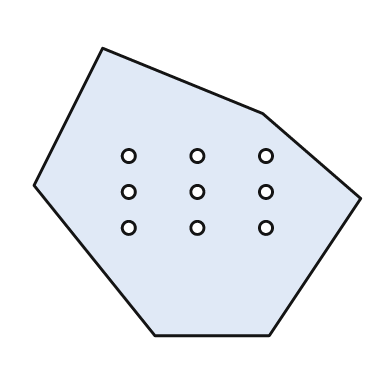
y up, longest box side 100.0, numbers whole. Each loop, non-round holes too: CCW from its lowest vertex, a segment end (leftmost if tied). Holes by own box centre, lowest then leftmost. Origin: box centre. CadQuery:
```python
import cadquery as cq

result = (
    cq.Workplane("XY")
    .moveTo(-13.0, -44.0)
    .lineTo(22.0, -44.0)
    .lineTo(50.0, -2.0)
    .lineTo(20.0, 24.0)
    .lineTo(-29.0, 44.0)
    .lineTo(-50.0, 2.0)
    .close()
    .moveTo(-21.0, -11.0)
    .circle(2.0)
    .moveTo(0.0, -11.0)
    .circle(2.0)
    .moveTo(21.0, -11.0)
    .circle(2.0)
    .moveTo(-21.0, 0.0)
    .circle(2.0)
    .moveTo(0.0, 0.0)
    .circle(2.0)
    .moveTo(21.0, 0.0)
    .circle(2.0)
    .moveTo(-21.0, 11.0)
    .circle(2.0)
    .moveTo(0.0, 11.0)
    .circle(2.0)
    .moveTo(21.0, 11.0)
    .circle(2.0)
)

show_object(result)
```